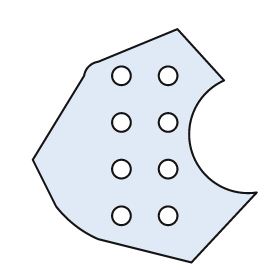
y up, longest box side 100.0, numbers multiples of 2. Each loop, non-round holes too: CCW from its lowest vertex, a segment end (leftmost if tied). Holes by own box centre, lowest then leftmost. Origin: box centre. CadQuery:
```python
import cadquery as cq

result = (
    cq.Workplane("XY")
    .moveTo(20.0, -50.0)
    .lineTo(48.0, -20.0)
    .threePointArc((20.0, -2.0), (34.0, 28.0))
    .lineTo(14.0, 50.0)
    .lineTo(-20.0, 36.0)
    .threePointArc((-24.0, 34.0), (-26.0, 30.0))
    .lineTo(-48.0, -6.0)
    .lineTo(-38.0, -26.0)
    .threePointArc((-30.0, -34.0), (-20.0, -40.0))
    .close()
    .moveTo(-10.0, -30.0)
    .circle(4.0)
    .moveTo(10.0, -30.0)
    .circle(4.0)
    .moveTo(-10.0, -10.0)
    .circle(4.0)
    .moveTo(10.0, -10.0)
    .circle(4.0)
    .moveTo(-10.0, 10.0)
    .circle(4.0)
    .moveTo(10.0, 10.0)
    .circle(4.0)
    .moveTo(-10.0, 30.0)
    .circle(4.0)
    .moveTo(10.0, 30.0)
    .circle(4.0)
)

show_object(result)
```